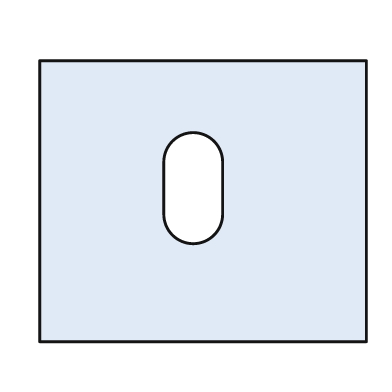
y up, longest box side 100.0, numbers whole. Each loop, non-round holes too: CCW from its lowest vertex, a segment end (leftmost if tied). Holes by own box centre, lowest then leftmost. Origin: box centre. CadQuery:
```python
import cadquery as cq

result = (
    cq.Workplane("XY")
    .moveTo(-50.0, -43.0)
    .lineTo(50.0, -43.0)
    .lineTo(50.0, 43.0)
    .lineTo(-50.0, 43.0)
    .close()
    .moveTo(-12.0, -4.0)
    .threePointArc((-3.0, -13.0), (6.0, -4.0))
    .lineTo(6.0, 12.0)
    .threePointArc((-3.0, 21.0), (-12.0, 12.0))
    .close()
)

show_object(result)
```